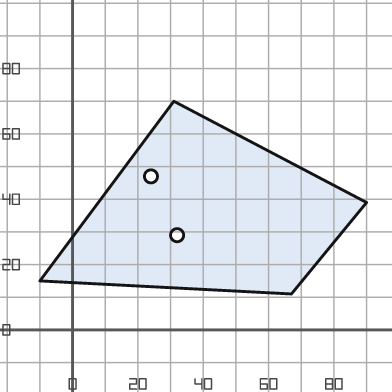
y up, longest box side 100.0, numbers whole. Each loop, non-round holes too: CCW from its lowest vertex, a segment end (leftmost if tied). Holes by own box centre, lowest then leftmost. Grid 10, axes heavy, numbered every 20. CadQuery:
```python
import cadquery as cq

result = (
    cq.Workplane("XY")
    .moveTo(67.0, 11.0)
    .lineTo(90.0, 39.0)
    .lineTo(31.0, 70.0)
    .lineTo(-10.0, 15.0)
    .close()
    .moveTo(32.0, 29.0)
    .circle(2.0)
    .moveTo(24.0, 47.0)
    .circle(2.0)
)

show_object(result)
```